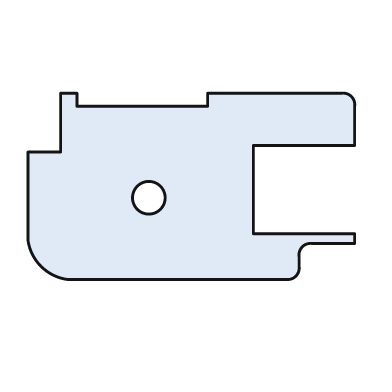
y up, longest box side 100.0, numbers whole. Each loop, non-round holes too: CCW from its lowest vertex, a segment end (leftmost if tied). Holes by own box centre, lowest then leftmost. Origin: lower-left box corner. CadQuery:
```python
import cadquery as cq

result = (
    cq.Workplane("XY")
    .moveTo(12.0, 0.0)
    .lineTo(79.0, 0.0)
    .threePointArc((82.0, 1.0), (83.0, 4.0))
    .lineTo(83.0, 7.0)
    .threePointArc((84.0, 10.0), (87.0, 11.0))
    .lineTo(100.0, 11.0)
    .lineTo(100.0, 14.0)
    .lineTo(69.0, 14.0)
    .lineTo(69.0, 41.0)
    .lineTo(100.0, 41.0)
    .lineTo(100.0, 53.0)
    .threePointArc((99.0, 56.0), (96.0, 57.0))
    .lineTo(55.0, 57.0)
    .lineTo(55.0, 53.0)
    .lineTo(15.0, 53.0)
    .lineTo(15.0, 57.0)
    .lineTo(10.0, 57.0)
    .lineTo(10.0, 39.0)
    .lineTo(0.0, 39.0)
    .lineTo(0.0, 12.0)
    .threePointArc((4.0, 4.0), (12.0, 0.0))
    .close()
    .moveTo(37.0, 25.0)
    .circle(5.0)
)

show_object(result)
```